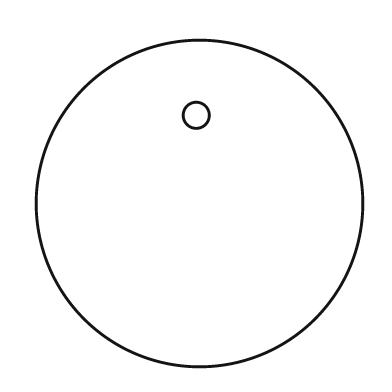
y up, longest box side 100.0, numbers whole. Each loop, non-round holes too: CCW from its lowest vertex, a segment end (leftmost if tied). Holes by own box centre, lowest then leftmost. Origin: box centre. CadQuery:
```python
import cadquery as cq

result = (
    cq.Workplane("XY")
    .moveTo(0.0, 0.0)
    .circle(50.0)
    .moveTo(-1.0, 27.0)
    .circle(4.0)
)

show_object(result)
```